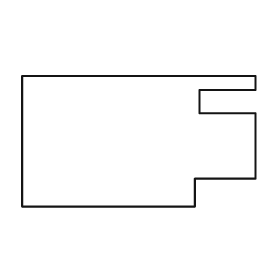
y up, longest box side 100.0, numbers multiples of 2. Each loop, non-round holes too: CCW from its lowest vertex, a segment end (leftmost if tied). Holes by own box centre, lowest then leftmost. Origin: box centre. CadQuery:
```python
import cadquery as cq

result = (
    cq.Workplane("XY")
    .moveTo(-50.0, -28.0)
    .lineTo(24.0, -28.0)
    .lineTo(24.0, -16.0)
    .lineTo(50.0, -16.0)
    .lineTo(50.0, 12.0)
    .lineTo(26.0, 12.0)
    .lineTo(26.0, 22.0)
    .lineTo(50.0, 22.0)
    .lineTo(50.0, 28.0)
    .lineTo(-50.0, 28.0)
    .close()
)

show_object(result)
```